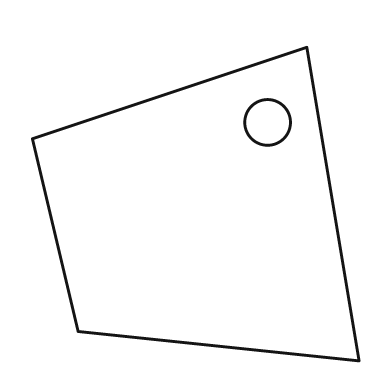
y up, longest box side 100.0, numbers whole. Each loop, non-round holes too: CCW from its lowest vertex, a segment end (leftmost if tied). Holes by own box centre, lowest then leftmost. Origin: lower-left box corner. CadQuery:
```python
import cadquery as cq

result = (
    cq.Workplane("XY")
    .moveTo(100.0, 0.0)
    .lineTo(84.0, 96.0)
    .lineTo(0.0, 68.0)
    .lineTo(14.0, 9.0)
    .close()
    .moveTo(72.0, 73.0)
    .circle(7.0)
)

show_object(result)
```